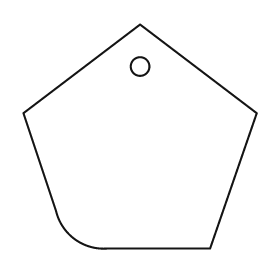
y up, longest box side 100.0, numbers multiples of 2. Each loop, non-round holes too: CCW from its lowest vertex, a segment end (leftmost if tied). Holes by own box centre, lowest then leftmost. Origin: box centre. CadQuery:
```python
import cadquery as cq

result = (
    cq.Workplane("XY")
    .moveTo(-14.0, -48.0)
    .lineTo(30.0, -48.0)
    .lineTo(50.0, 10.0)
    .lineTo(0.0, 48.0)
    .lineTo(-50.0, 10.0)
    .lineTo(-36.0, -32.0)
    .threePointArc((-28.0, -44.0), (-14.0, -48.0))
    .close()
    .moveTo(0.0, 30.0)
    .circle(4.0)
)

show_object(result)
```